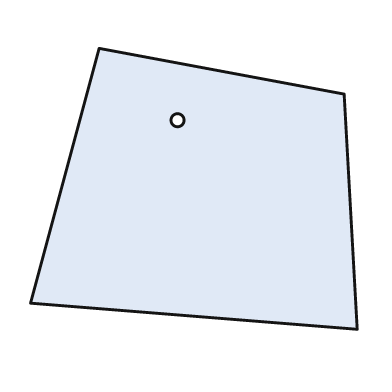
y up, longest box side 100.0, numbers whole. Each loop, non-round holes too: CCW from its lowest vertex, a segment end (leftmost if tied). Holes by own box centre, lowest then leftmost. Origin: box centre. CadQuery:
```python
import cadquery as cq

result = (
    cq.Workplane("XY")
    .moveTo(50.0, -43.0)
    .lineTo(46.0, 29.0)
    .lineTo(-29.0, 43.0)
    .lineTo(-50.0, -35.0)
    .close()
    .moveTo(-5.0, 21.0)
    .circle(2.0)
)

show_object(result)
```